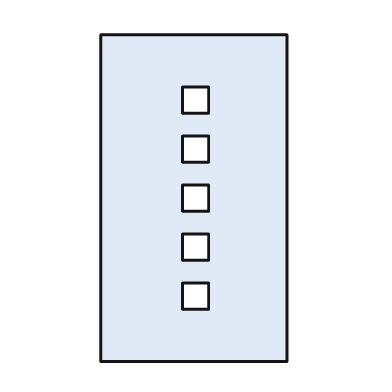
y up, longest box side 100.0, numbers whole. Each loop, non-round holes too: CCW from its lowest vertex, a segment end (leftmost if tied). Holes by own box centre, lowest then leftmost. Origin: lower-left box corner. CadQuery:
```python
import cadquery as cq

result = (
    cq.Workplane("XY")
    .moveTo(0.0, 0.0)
    .lineTo(57.0, 0.0)
    .lineTo(57.0, 100.0)
    .lineTo(0.0, 100.0)
    .close()
    .moveTo(25.0, 16.0)
    .lineTo(33.0, 16.0)
    .lineTo(33.0, 24.0)
    .lineTo(25.0, 24.0)
    .close()
    .moveTo(25.0, 31.0)
    .lineTo(33.0, 31.0)
    .lineTo(33.0, 39.0)
    .lineTo(25.0, 39.0)
    .close()
    .moveTo(25.0, 46.0)
    .lineTo(33.0, 46.0)
    .lineTo(33.0, 54.0)
    .lineTo(25.0, 54.0)
    .close()
    .moveTo(25.0, 61.0)
    .lineTo(33.0, 61.0)
    .lineTo(33.0, 69.0)
    .lineTo(25.0, 69.0)
    .close()
    .moveTo(25.0, 76.0)
    .lineTo(33.0, 76.0)
    .lineTo(33.0, 84.0)
    .lineTo(25.0, 84.0)
    .close()
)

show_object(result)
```